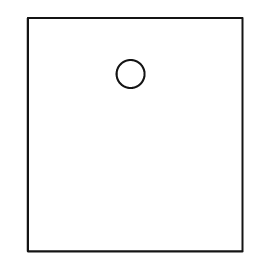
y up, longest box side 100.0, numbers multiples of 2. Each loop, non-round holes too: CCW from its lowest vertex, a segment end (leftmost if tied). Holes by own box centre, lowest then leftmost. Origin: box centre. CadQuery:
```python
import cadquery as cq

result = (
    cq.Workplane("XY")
    .moveTo(-46.0, -50.0)
    .lineTo(46.0, -50.0)
    .lineTo(46.0, 50.0)
    .lineTo(-46.0, 50.0)
    .close()
    .moveTo(-2.0, 26.0)
    .circle(6.0)
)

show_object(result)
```